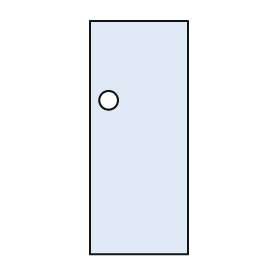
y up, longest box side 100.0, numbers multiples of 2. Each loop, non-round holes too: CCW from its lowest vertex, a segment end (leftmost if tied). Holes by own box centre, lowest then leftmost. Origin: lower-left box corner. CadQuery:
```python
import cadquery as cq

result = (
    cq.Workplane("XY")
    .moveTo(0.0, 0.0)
    .lineTo(42.0, 0.0)
    .lineTo(42.0, 100.0)
    .lineTo(0.0, 100.0)
    .close()
    .moveTo(8.0, 66.0)
    .circle(4.0)
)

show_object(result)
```